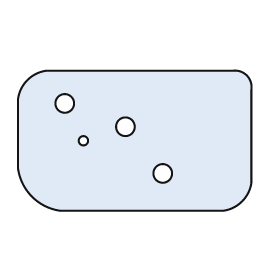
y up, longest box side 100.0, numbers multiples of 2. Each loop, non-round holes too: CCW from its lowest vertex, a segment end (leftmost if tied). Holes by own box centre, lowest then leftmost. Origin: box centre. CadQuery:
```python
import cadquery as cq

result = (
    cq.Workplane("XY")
    .moveTo(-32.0, -30.0)
    .lineTo(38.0, -30.0)
    .threePointArc((46.0, -26.0), (50.0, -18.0))
    .lineTo(50.0, 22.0)
    .threePointArc((48.0, 28.0), (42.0, 30.0))
    .lineTo(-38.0, 30.0)
    .threePointArc((-46.0, 26.0), (-50.0, 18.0))
    .lineTo(-50.0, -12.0)
    .threePointArc((-44.0, -24.0), (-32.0, -30.0))
    .close()
    .moveTo(12.0, -14.0)
    .circle(4.0)
    .moveTo(-22.0, 0.0)
    .circle(2.0)
    .moveTo(-4.0, 6.0)
    .circle(4.0)
    .moveTo(-30.0, 16.0)
    .circle(4.0)
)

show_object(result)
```